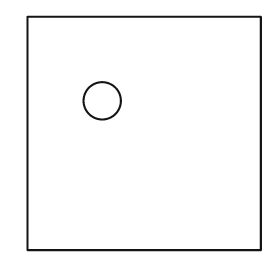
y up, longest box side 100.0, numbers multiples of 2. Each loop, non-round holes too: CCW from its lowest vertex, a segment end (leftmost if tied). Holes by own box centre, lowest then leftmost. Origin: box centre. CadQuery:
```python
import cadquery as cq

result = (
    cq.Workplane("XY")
    .moveTo(-50.0, -50.0)
    .lineTo(50.0, -50.0)
    .lineTo(50.0, 50.0)
    .lineTo(-50.0, 50.0)
    .close()
    .moveTo(-18.0, 14.0)
    .circle(8.0)
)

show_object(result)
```